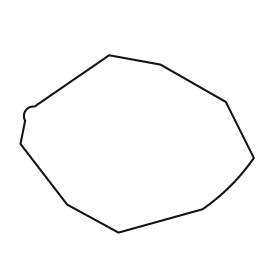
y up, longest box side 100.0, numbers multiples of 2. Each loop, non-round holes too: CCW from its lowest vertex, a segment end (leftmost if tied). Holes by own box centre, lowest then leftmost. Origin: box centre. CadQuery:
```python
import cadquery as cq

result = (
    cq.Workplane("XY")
    .moveTo(-8.0, -38.0)
    .lineTo(28.0, -28.0)
    .threePointArc((40.0, -18.0), (50.0, -6.0))
    .lineTo(38.0, 18.0)
    .lineTo(10.0, 34.0)
    .lineTo(-12.0, 38.0)
    .lineTo(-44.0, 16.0)
    .threePointArc((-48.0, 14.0), (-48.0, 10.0))
    .lineTo(-50.0, 0.0)
    .lineTo(-30.0, -26.0)
    .close()
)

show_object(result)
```